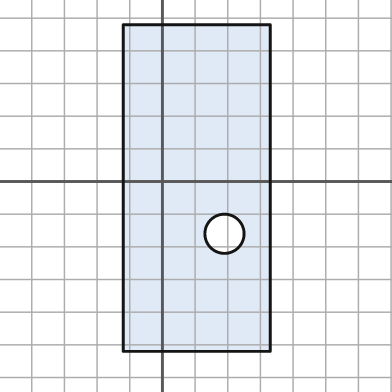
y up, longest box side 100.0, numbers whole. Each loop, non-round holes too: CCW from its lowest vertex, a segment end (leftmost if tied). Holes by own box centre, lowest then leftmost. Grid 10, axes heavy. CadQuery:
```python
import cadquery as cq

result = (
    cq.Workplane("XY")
    .moveTo(-12.0, -52.0)
    .lineTo(33.0, -52.0)
    .lineTo(33.0, 48.0)
    .lineTo(-12.0, 48.0)
    .close()
    .moveTo(19.0, -16.0)
    .circle(6.0)
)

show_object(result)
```